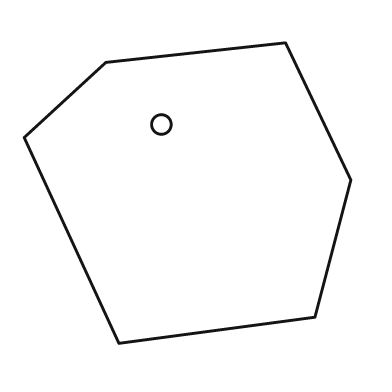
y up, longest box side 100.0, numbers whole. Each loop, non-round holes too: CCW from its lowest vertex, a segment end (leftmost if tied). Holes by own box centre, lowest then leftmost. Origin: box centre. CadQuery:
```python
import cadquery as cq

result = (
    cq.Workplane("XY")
    .moveTo(-21.0, -46.0)
    .lineTo(39.0, -38.0)
    .lineTo(50.0, 4.0)
    .lineTo(30.0, 46.0)
    .lineTo(-25.0, 40.0)
    .lineTo(-50.0, 17.0)
    .close()
    .moveTo(-8.0, 21.0)
    .circle(3.0)
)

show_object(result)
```